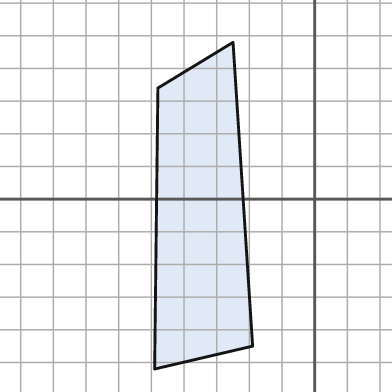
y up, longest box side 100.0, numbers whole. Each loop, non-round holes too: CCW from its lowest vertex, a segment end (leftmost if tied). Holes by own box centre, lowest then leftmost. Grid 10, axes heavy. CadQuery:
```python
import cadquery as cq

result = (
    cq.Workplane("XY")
    .moveTo(-49.0, -52.0)
    .lineTo(-19.0, -45.0)
    .lineTo(-25.0, 48.0)
    .lineTo(-48.0, 34.0)
    .close()
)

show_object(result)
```